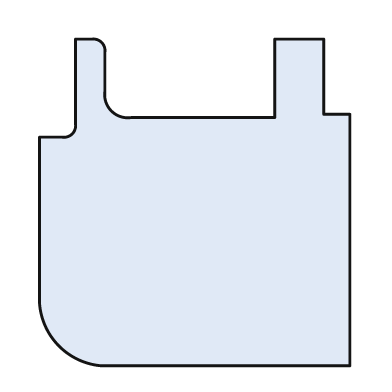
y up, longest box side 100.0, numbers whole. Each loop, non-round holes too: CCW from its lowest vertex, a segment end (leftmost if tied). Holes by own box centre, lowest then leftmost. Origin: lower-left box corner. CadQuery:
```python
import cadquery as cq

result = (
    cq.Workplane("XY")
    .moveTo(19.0, 0.0)
    .lineTo(95.0, 0.0)
    .lineTo(95.0, 77.0)
    .lineTo(87.0, 77.0)
    .lineTo(87.0, 100.0)
    .lineTo(72.0, 100.0)
    .lineTo(72.0, 76.0)
    .lineTo(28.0, 76.0)
    .threePointArc((22.0, 78.0), (20.0, 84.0))
    .lineTo(20.0, 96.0)
    .threePointArc((19.0, 99.0), (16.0, 100.0))
    .lineTo(11.0, 100.0)
    .lineTo(11.0, 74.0)
    .threePointArc((10.0, 71.0), (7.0, 70.0))
    .lineTo(0.0, 70.0)
    .lineTo(0.0, 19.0)
    .threePointArc((6.0, 6.0), (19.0, 0.0))
    .close()
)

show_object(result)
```